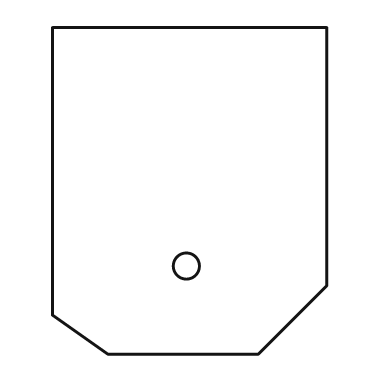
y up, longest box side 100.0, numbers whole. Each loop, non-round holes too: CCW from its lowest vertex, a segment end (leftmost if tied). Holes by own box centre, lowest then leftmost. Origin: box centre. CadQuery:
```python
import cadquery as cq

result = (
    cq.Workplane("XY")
    .moveTo(-25.0, -50.0)
    .lineTo(21.0, -50.0)
    .lineTo(42.0, -29.0)
    .lineTo(42.0, 50.0)
    .lineTo(-42.0, 50.0)
    .lineTo(-42.0, -38.0)
    .close()
    .moveTo(-1.0, -23.0)
    .circle(4.0)
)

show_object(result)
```